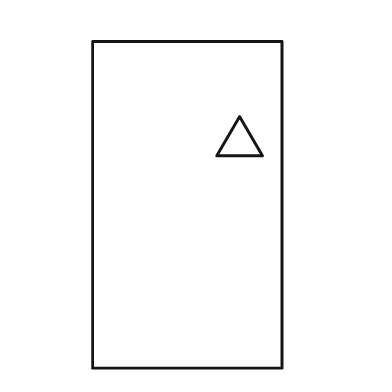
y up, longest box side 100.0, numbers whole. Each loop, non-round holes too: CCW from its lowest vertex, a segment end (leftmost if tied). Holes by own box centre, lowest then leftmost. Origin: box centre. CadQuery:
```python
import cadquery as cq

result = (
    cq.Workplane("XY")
    .moveTo(-29.0, -50.0)
    .lineTo(29.0, -50.0)
    .lineTo(29.0, 50.0)
    .lineTo(-29.0, 50.0)
    .close()
    .moveTo(9.0, 15.0)
    .lineTo(23.0, 15.0)
    .lineTo(16.0, 27.0)
    .close()
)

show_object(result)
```